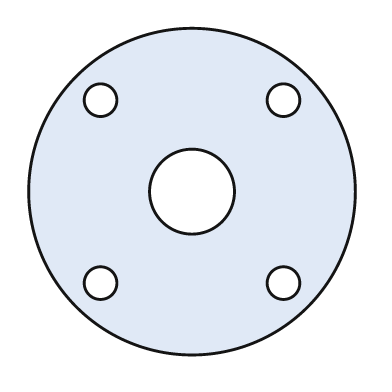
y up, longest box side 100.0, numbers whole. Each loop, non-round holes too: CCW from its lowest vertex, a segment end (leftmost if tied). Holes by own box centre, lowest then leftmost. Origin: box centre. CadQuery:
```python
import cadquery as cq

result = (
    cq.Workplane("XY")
    .moveTo(0.0, 0.0)
    .circle(50.0)
    .moveTo(-28.0, -28.0)
    .circle(5.0)
    .moveTo(28.0, -28.0)
    .circle(5.0)
    .moveTo(0.0, 0.0)
    .circle(13.0)
    .moveTo(-28.0, 28.0)
    .circle(5.0)
    .moveTo(28.0, 28.0)
    .circle(5.0)
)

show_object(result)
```